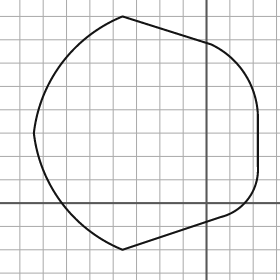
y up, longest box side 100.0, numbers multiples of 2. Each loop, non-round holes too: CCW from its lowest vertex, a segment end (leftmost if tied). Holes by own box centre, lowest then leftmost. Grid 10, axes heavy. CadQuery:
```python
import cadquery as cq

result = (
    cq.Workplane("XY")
    .moveTo(-36.0, -20.0)
    .lineTo(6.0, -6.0)
    .threePointArc((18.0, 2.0), (22.0, 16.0))
    .lineTo(22.0, 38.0)
    .threePointArc((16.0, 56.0), (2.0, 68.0))
    .lineTo(-36.0, 80.0)
    .threePointArc((-62.0, 60.0), (-74.0, 30.0))
    .threePointArc((-62.0, 0.0), (-36.0, -20.0))
    .close()
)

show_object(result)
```